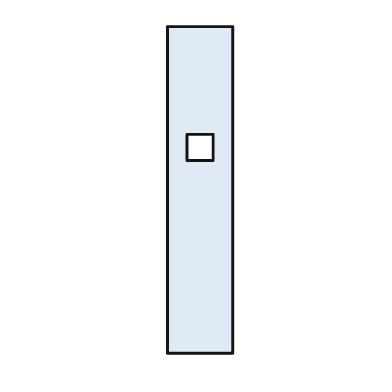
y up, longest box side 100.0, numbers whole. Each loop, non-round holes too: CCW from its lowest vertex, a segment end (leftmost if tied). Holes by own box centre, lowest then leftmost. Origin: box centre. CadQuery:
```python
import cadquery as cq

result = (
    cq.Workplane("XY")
    .moveTo(-10.0, -50.0)
    .lineTo(10.0, -50.0)
    .lineTo(10.0, 50.0)
    .lineTo(-10.0, 50.0)
    .close()
    .moveTo(-4.0, 9.0)
    .lineTo(4.0, 9.0)
    .lineTo(4.0, 17.0)
    .lineTo(-4.0, 17.0)
    .close()
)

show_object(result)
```